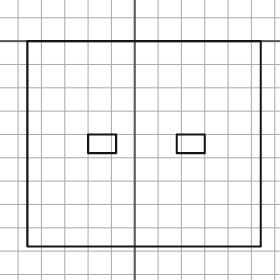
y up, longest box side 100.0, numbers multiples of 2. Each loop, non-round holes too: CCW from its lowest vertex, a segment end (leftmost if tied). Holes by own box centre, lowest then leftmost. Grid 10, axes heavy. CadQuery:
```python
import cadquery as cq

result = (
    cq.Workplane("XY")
    .moveTo(-46.0, -88.0)
    .lineTo(54.0, -88.0)
    .lineTo(54.0, 0.0)
    .lineTo(-46.0, 0.0)
    .close()
    .moveTo(-20.0, -48.0)
    .lineTo(-8.0, -48.0)
    .lineTo(-8.0, -40.0)
    .lineTo(-20.0, -40.0)
    .close()
    .moveTo(18.0, -48.0)
    .lineTo(30.0, -48.0)
    .lineTo(30.0, -40.0)
    .lineTo(18.0, -40.0)
    .close()
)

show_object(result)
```